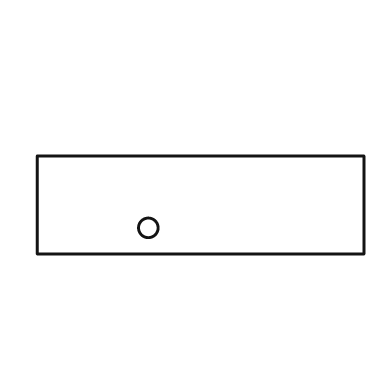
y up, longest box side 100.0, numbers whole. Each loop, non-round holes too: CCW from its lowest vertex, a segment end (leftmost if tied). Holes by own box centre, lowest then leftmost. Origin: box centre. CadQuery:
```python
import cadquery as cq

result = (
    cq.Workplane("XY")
    .moveTo(-50.0, -15.0)
    .lineTo(50.0, -15.0)
    .lineTo(50.0, 15.0)
    .lineTo(-50.0, 15.0)
    .close()
    .moveTo(-16.0, -7.0)
    .circle(3.0)
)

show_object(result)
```